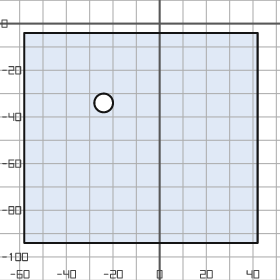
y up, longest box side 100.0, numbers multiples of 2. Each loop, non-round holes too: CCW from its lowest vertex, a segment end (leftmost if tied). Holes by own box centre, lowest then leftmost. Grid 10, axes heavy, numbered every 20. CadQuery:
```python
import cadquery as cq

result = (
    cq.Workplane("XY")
    .moveTo(-58.0, -94.0)
    .lineTo(42.0, -94.0)
    .lineTo(42.0, -4.0)
    .lineTo(-58.0, -4.0)
    .close()
    .moveTo(-24.0, -34.0)
    .circle(4.0)
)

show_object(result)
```